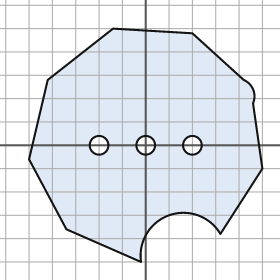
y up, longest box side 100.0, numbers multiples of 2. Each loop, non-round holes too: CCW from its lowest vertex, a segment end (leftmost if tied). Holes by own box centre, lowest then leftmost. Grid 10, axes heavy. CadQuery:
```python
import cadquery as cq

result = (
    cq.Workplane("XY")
    .moveTo(-2.0, -50.0)
    .threePointArc((10.0, -30.0), (32.0, -38.0))
    .lineTo(50.0, -10.0)
    .lineTo(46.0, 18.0)
    .threePointArc((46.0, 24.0), (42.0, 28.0))
    .lineTo(20.0, 48.0)
    .lineTo(-14.0, 50.0)
    .lineTo(-42.0, 28.0)
    .lineTo(-50.0, -6.0)
    .lineTo(-34.0, -36.0)
    .close()
    .moveTo(-20.0, 0.0)
    .circle(4.0)
    .moveTo(0.0, 0.0)
    .circle(4.0)
    .moveTo(20.0, 0.0)
    .circle(4.0)
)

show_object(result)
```